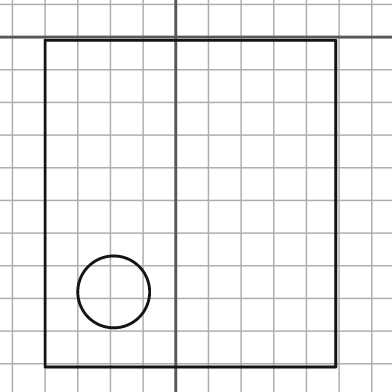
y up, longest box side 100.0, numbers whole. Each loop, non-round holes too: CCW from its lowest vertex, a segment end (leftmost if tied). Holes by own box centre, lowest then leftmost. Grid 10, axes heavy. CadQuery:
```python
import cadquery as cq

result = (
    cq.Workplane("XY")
    .moveTo(-40.0, -101.0)
    .lineTo(49.0, -101.0)
    .lineTo(49.0, -1.0)
    .lineTo(-40.0, -1.0)
    .close()
    .moveTo(-19.0, -78.0)
    .circle(11.0)
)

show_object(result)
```